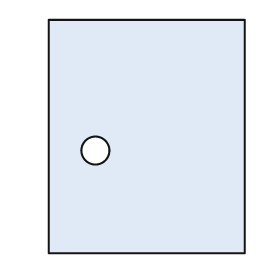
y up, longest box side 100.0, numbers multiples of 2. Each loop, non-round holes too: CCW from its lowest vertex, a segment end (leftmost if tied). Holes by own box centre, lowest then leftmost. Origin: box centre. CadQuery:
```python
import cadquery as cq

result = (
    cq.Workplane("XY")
    .moveTo(-42.0, -50.0)
    .lineTo(42.0, -50.0)
    .lineTo(42.0, 50.0)
    .lineTo(-42.0, 50.0)
    .close()
    .moveTo(-22.0, -6.0)
    .circle(6.0)
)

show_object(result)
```